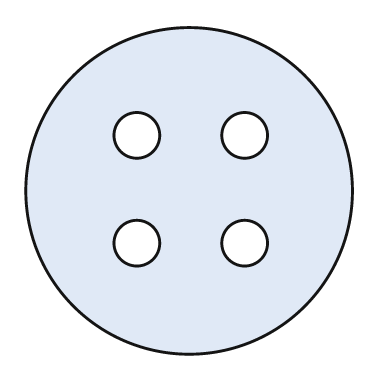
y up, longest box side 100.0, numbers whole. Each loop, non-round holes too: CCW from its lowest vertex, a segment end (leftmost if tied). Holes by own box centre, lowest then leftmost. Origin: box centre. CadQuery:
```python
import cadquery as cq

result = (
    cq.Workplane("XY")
    .moveTo(0.0, 0.0)
    .circle(50.0)
    .moveTo(-16.0, -16.0)
    .circle(7.0)
    .moveTo(17.0, -16.0)
    .circle(7.0)
    .moveTo(-16.0, 17.0)
    .circle(7.0)
    .moveTo(17.0, 17.0)
    .circle(7.0)
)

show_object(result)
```